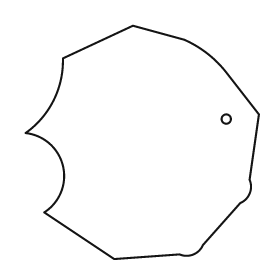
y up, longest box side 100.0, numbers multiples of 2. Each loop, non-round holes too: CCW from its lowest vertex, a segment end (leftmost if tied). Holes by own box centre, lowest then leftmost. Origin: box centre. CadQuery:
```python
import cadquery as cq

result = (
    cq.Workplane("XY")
    .moveTo(-12.0, -50.0)
    .lineTo(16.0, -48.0)
    .threePointArc((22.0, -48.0), (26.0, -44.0))
    .lineTo(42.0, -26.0)
    .threePointArc((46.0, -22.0), (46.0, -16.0))
    .lineTo(50.0, 12.0)
    .lineTo(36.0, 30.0)
    .threePointArc((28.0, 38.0), (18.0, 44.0))
    .lineTo(-4.0, 50.0)
    .lineTo(-34.0, 36.0)
    .threePointArc((-38.0, 18.0), (-50.0, 4.0))
    .threePointArc((-34.0, -10.0), (-42.0, -30.0))
    .close()
    .moveTo(36.0, 10.0)
    .circle(2.0)
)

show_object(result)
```